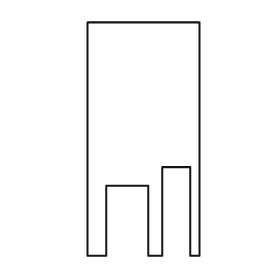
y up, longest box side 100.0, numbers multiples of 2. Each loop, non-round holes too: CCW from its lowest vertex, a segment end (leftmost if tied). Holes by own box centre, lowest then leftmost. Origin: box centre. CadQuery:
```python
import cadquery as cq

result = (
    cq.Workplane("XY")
    .moveTo(-24.0, -50.0)
    .lineTo(-16.0, -50.0)
    .lineTo(-16.0, -20.0)
    .lineTo(2.0, -20.0)
    .lineTo(2.0, -50.0)
    .lineTo(8.0, -50.0)
    .lineTo(8.0, -12.0)
    .lineTo(20.0, -12.0)
    .lineTo(20.0, -50.0)
    .lineTo(24.0, -50.0)
    .lineTo(24.0, 50.0)
    .lineTo(-24.0, 50.0)
    .close()
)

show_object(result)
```